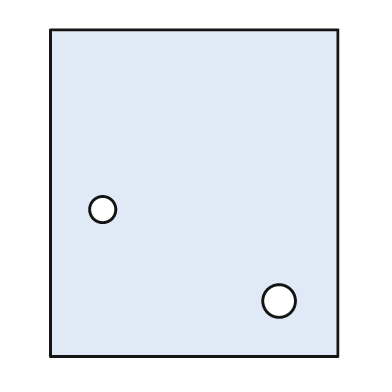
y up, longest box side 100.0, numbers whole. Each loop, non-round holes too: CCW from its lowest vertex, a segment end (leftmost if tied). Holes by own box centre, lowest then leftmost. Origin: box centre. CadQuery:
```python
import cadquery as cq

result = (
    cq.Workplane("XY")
    .moveTo(-44.0, -50.0)
    .lineTo(44.0, -50.0)
    .lineTo(44.0, 50.0)
    .lineTo(-44.0, 50.0)
    .close()
    .moveTo(26.0, -33.0)
    .circle(5.0)
    .moveTo(-28.0, -5.0)
    .circle(4.0)
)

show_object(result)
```